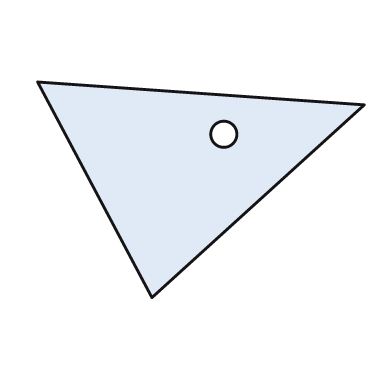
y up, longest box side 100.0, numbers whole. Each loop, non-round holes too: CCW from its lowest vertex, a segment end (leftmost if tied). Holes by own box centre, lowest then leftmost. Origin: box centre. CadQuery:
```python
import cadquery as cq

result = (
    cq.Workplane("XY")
    .moveTo(-15.0, -33.0)
    .lineTo(50.0, 26.0)
    .lineTo(-50.0, 33.0)
    .close()
    .moveTo(7.0, 17.0)
    .circle(4.0)
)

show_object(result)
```